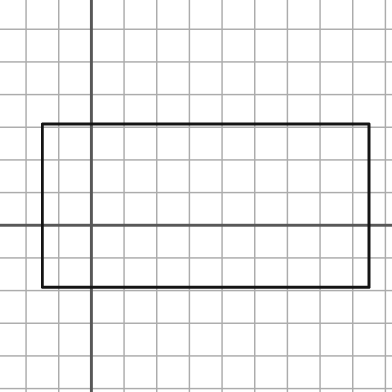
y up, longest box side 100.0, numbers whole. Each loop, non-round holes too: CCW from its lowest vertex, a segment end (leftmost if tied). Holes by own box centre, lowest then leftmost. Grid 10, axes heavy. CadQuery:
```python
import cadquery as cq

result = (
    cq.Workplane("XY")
    .moveTo(-15.0, -19.0)
    .lineTo(85.0, -19.0)
    .lineTo(85.0, 31.0)
    .lineTo(-15.0, 31.0)
    .close()
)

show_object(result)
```